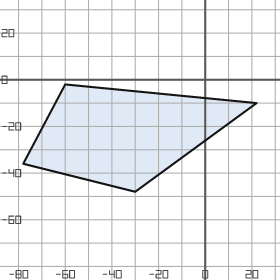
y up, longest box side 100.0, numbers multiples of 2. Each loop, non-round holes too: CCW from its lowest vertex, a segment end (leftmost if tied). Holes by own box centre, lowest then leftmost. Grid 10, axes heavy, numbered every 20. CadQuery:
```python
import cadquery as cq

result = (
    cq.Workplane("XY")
    .moveTo(-30.0, -48.0)
    .lineTo(22.0, -10.0)
    .lineTo(-60.0, -2.0)
    .lineTo(-78.0, -36.0)
    .close()
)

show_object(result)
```